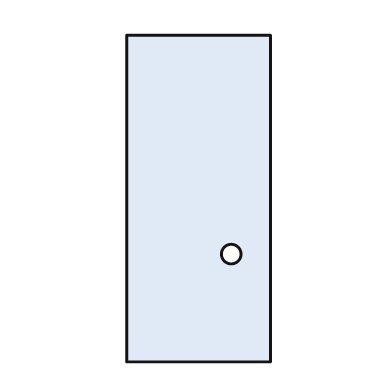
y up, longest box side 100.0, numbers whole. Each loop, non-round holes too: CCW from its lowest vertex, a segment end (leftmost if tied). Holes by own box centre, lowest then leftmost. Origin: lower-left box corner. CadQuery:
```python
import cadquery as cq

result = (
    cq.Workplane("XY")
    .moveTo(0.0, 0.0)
    .lineTo(44.0, 0.0)
    .lineTo(44.0, 100.0)
    .lineTo(0.0, 100.0)
    .close()
    .moveTo(32.0, 33.0)
    .circle(3.0)
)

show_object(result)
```